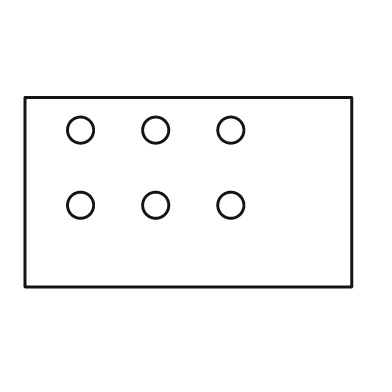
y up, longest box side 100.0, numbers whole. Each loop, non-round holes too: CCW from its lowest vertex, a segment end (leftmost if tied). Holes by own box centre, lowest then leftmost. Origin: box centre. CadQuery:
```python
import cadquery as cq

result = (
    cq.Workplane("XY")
    .moveTo(-50.0, -29.0)
    .lineTo(50.0, -29.0)
    .lineTo(50.0, 29.0)
    .lineTo(-50.0, 29.0)
    .close()
    .moveTo(-33.0, -4.0)
    .circle(4.0)
    .moveTo(-10.0, -4.0)
    .circle(4.0)
    .moveTo(13.0, -4.0)
    .circle(4.0)
    .moveTo(-33.0, 19.0)
    .circle(4.0)
    .moveTo(-10.0, 19.0)
    .circle(4.0)
    .moveTo(13.0, 19.0)
    .circle(4.0)
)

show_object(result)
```